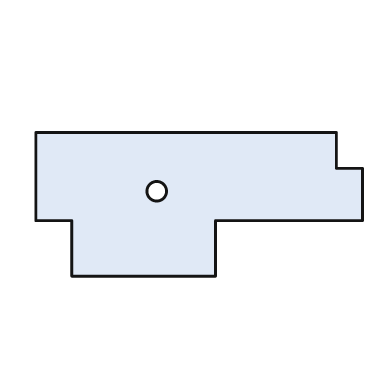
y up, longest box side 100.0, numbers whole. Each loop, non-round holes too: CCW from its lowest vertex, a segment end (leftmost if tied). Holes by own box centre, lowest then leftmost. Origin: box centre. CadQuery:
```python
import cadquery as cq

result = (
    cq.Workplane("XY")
    .moveTo(-39.0, -22.0)
    .lineTo(5.0, -22.0)
    .lineTo(5.0, -5.0)
    .lineTo(50.0, -5.0)
    .lineTo(50.0, 11.0)
    .lineTo(42.0, 11.0)
    .lineTo(42.0, 22.0)
    .lineTo(-50.0, 22.0)
    .lineTo(-50.0, -5.0)
    .lineTo(-39.0, -5.0)
    .close()
    .moveTo(-13.0, 4.0)
    .circle(3.0)
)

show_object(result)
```